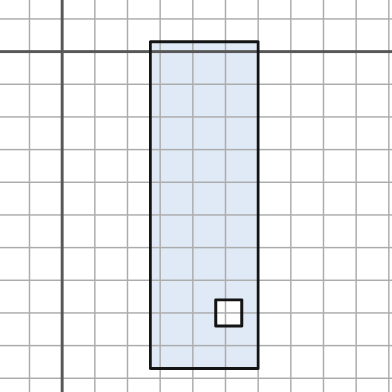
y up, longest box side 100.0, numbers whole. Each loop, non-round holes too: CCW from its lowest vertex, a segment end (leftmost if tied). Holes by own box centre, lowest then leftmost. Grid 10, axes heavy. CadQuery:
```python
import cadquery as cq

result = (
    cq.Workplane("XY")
    .moveTo(27.0, -97.0)
    .lineTo(60.0, -97.0)
    .lineTo(60.0, 3.0)
    .lineTo(27.0, 3.0)
    .close()
    .moveTo(47.0, -84.0)
    .lineTo(55.0, -84.0)
    .lineTo(55.0, -76.0)
    .lineTo(47.0, -76.0)
    .close()
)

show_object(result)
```